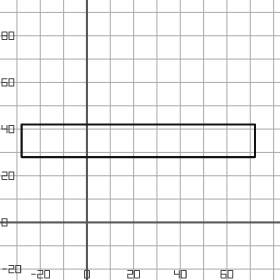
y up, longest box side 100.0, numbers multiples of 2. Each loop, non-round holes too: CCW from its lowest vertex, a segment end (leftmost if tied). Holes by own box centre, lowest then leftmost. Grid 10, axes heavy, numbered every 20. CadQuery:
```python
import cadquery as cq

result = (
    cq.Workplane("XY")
    .moveTo(-28.0, 28.0)
    .lineTo(72.0, 28.0)
    .lineTo(72.0, 42.0)
    .lineTo(-28.0, 42.0)
    .close()
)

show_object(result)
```